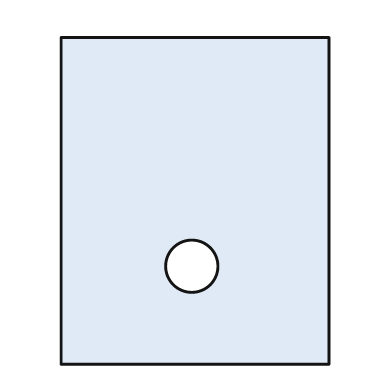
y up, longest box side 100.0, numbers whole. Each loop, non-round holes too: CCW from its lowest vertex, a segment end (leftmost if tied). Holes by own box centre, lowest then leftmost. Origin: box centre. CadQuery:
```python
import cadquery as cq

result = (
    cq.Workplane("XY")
    .moveTo(-41.0, -50.0)
    .lineTo(41.0, -50.0)
    .lineTo(41.0, 50.0)
    .lineTo(-41.0, 50.0)
    .close()
    .moveTo(-1.0, -20.0)
    .circle(8.0)
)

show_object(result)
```